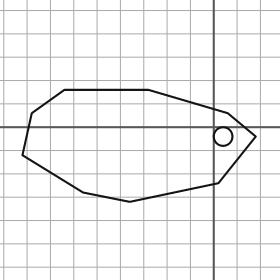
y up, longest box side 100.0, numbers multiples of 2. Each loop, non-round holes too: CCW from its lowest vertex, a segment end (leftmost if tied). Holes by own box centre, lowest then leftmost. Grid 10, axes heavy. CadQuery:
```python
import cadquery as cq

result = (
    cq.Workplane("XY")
    .moveTo(-36.0, -32.0)
    .lineTo(2.0, -24.0)
    .lineTo(18.0, -4.0)
    .lineTo(6.0, 6.0)
    .lineTo(-28.0, 16.0)
    .lineTo(-64.0, 16.0)
    .lineTo(-78.0, 6.0)
    .lineTo(-82.0, -12.0)
    .lineTo(-56.0, -28.0)
    .close()
    .moveTo(4.0, -4.0)
    .circle(4.0)
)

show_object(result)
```